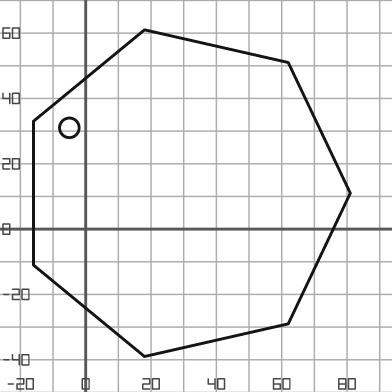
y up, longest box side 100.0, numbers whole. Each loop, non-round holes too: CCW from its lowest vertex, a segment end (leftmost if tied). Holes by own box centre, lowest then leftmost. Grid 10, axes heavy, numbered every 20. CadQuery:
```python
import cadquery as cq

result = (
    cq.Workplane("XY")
    .moveTo(18.0, -39.0)
    .lineTo(62.0, -29.0)
    .lineTo(81.0, 11.0)
    .lineTo(62.0, 51.0)
    .lineTo(18.0, 61.0)
    .lineTo(-16.0, 33.0)
    .lineTo(-16.0, -11.0)
    .close()
    .moveTo(-5.0, 31.0)
    .circle(3.0)
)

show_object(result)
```